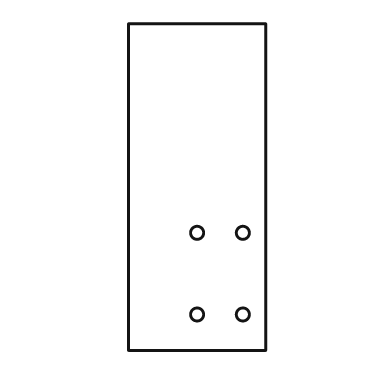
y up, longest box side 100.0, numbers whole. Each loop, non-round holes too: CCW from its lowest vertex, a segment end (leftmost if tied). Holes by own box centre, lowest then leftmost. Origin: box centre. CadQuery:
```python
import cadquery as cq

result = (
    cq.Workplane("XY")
    .moveTo(-21.0, -50.0)
    .lineTo(21.0, -50.0)
    .lineTo(21.0, 50.0)
    .lineTo(-21.0, 50.0)
    .close()
    .moveTo(0.0, -39.0)
    .circle(2.0)
    .moveTo(14.0, -39.0)
    .circle(2.0)
    .moveTo(0.0, -14.0)
    .circle(2.0)
    .moveTo(14.0, -14.0)
    .circle(2.0)
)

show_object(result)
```